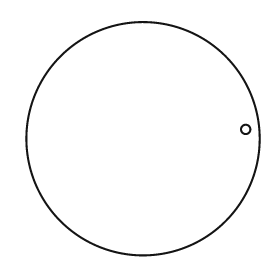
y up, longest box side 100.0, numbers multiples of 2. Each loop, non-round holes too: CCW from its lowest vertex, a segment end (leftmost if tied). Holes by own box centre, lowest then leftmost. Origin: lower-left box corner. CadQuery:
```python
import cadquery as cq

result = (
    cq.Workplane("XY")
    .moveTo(50.0, 50.0)
    .circle(50.0)
    .moveTo(94.0, 54.0)
    .circle(2.0)
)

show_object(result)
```